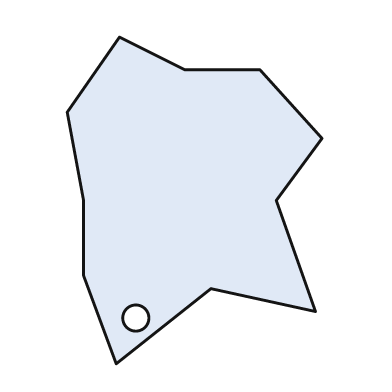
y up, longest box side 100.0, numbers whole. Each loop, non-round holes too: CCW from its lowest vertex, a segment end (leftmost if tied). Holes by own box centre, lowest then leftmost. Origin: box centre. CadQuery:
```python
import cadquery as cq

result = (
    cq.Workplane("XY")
    .moveTo(-24.0, -50.0)
    .lineTo(5.0, -27.0)
    .lineTo(37.0, -34.0)
    .lineTo(25.0, 0.0)
    .lineTo(39.0, 19.0)
    .lineTo(20.0, 40.0)
    .lineTo(-3.0, 40.0)
    .lineTo(-23.0, 50.0)
    .lineTo(-39.0, 27.0)
    .lineTo(-34.0, 0.0)
    .lineTo(-34.0, -23.0)
    .close()
    .moveTo(-18.0, -36.0)
    .circle(4.0)
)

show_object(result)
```